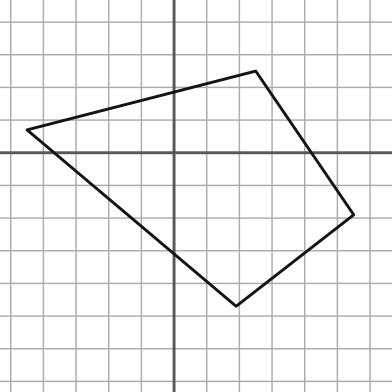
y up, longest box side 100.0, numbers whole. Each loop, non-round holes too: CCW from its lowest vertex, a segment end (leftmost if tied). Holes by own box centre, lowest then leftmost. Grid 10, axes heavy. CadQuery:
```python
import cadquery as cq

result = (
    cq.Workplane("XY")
    .moveTo(19.0, -47.0)
    .lineTo(55.0, -19.0)
    .lineTo(25.0, 25.0)
    .lineTo(-45.0, 7.0)
    .close()
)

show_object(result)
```